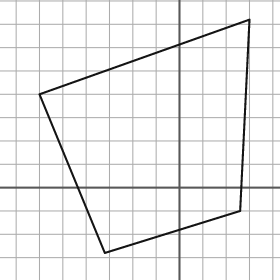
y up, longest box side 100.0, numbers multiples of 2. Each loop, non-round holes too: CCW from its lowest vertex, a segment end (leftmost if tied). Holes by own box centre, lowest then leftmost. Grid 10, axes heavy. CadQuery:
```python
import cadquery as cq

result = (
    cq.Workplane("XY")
    .moveTo(-32.0, -28.0)
    .lineTo(26.0, -10.0)
    .lineTo(30.0, 72.0)
    .lineTo(-60.0, 40.0)
    .close()
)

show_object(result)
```